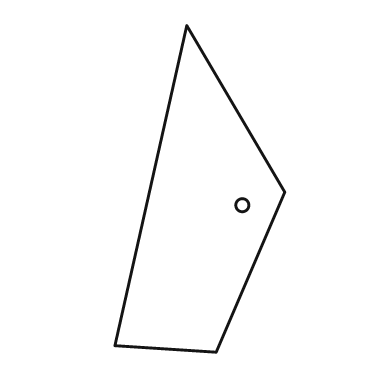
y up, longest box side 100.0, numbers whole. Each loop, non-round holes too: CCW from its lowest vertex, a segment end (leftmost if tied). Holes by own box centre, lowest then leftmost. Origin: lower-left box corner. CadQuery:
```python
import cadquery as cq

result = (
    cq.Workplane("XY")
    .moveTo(31.0, 0.0)
    .lineTo(52.0, 49.0)
    .lineTo(22.0, 100.0)
    .lineTo(0.0, 2.0)
    .close()
    .moveTo(39.0, 45.0)
    .circle(2.0)
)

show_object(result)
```